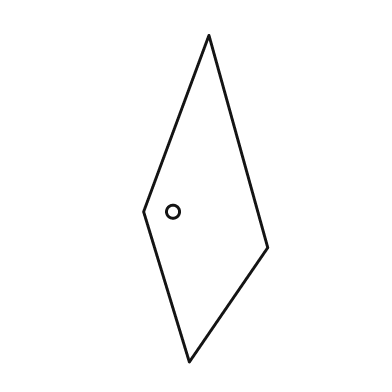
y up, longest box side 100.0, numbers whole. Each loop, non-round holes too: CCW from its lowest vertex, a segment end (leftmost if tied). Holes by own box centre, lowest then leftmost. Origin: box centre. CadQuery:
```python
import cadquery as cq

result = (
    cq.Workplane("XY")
    .moveTo(-5.0, -50.0)
    .lineTo(19.0, -15.0)
    .lineTo(1.0, 50.0)
    .lineTo(-19.0, -4.0)
    .close()
    .moveTo(-10.0, -4.0)
    .circle(2.0)
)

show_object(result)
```